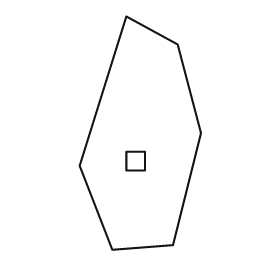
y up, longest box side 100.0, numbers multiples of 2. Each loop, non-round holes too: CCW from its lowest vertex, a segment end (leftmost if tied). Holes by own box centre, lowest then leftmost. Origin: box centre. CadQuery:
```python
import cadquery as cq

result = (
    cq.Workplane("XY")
    .moveTo(-12.0, -50.0)
    .lineTo(14.0, -48.0)
    .lineTo(26.0, 0.0)
    .lineTo(16.0, 38.0)
    .lineTo(-6.0, 50.0)
    .lineTo(-26.0, -14.0)
    .close()
    .moveTo(-6.0, -16.0)
    .lineTo(2.0, -16.0)
    .lineTo(2.0, -8.0)
    .lineTo(-6.0, -8.0)
    .close()
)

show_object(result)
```